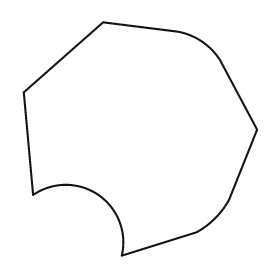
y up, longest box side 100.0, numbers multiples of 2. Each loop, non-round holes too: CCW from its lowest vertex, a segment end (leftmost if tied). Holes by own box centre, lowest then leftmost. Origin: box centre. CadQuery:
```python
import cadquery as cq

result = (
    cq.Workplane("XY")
    .moveTo(-8.0, -50.0)
    .lineTo(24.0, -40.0)
    .threePointArc((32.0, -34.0), (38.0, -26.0))
    .lineTo(50.0, 4.0)
    .lineTo(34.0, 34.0)
    .threePointArc((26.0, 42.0), (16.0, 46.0))
    .lineTo(-16.0, 50.0)
    .lineTo(-50.0, 20.0)
    .lineTo(-46.0, -24.0)
    .threePointArc((-18.0, -24.0), (-8.0, -50.0))
    .close()
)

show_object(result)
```